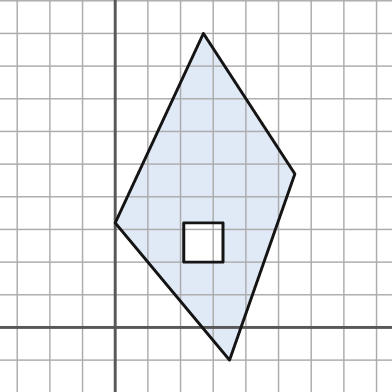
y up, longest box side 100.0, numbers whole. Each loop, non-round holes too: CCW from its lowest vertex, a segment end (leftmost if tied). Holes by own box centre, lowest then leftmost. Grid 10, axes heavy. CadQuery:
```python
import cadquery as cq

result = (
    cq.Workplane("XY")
    .moveTo(35.0, -10.0)
    .lineTo(55.0, 47.0)
    .lineTo(27.0, 90.0)
    .lineTo(0.0, 32.0)
    .close()
    .moveTo(21.0, 20.0)
    .lineTo(33.0, 20.0)
    .lineTo(33.0, 32.0)
    .lineTo(21.0, 32.0)
    .close()
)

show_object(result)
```